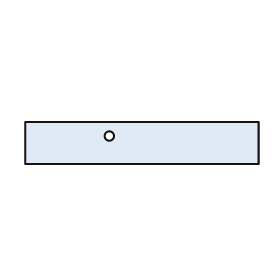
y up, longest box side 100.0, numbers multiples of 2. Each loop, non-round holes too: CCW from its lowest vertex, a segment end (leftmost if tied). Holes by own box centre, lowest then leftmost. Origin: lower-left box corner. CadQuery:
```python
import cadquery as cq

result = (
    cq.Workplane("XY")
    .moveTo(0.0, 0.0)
    .lineTo(100.0, 0.0)
    .lineTo(100.0, 18.0)
    .lineTo(0.0, 18.0)
    .close()
    .moveTo(36.0, 12.0)
    .circle(2.0)
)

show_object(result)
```